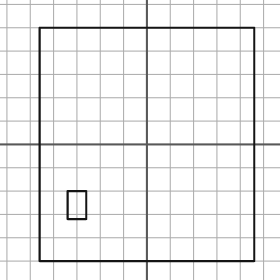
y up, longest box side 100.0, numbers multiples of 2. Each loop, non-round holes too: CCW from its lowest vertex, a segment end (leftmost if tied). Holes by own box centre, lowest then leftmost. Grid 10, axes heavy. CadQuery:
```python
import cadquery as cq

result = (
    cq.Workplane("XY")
    .moveTo(-46.0, -50.0)
    .lineTo(46.0, -50.0)
    .lineTo(46.0, 50.0)
    .lineTo(-46.0, 50.0)
    .close()
    .moveTo(-34.0, -32.0)
    .lineTo(-26.0, -32.0)
    .lineTo(-26.0, -20.0)
    .lineTo(-34.0, -20.0)
    .close()
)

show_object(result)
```